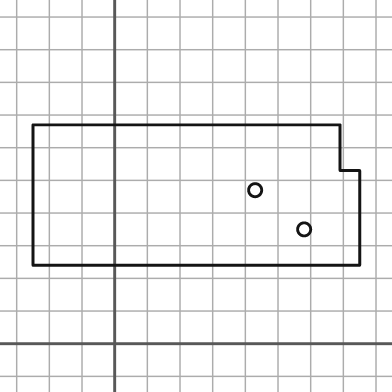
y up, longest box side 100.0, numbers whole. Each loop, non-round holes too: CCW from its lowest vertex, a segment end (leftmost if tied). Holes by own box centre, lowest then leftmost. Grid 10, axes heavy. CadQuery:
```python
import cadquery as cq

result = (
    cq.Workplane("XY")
    .moveTo(-25.0, 24.0)
    .lineTo(75.0, 24.0)
    .lineTo(75.0, 53.0)
    .lineTo(69.0, 53.0)
    .lineTo(69.0, 67.0)
    .lineTo(-25.0, 67.0)
    .close()
    .moveTo(58.0, 35.0)
    .circle(2.0)
    .moveTo(43.0, 47.0)
    .circle(2.0)
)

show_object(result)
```